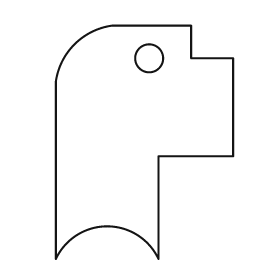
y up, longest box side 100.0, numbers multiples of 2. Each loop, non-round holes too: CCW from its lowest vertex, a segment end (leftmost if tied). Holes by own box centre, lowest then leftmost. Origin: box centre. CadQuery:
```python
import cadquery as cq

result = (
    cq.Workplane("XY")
    .moveTo(-38.0, -50.0)
    .threePointArc((-16.0, -36.0), (6.0, -50.0))
    .lineTo(6.0, -6.0)
    .lineTo(38.0, -6.0)
    .lineTo(38.0, 36.0)
    .lineTo(20.0, 36.0)
    .lineTo(20.0, 50.0)
    .lineTo(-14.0, 50.0)
    .threePointArc((-30.0, 42.0), (-38.0, 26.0))
    .close()
    .moveTo(2.0, 36.0)
    .circle(6.0)
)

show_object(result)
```